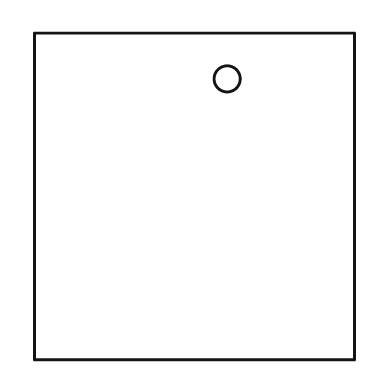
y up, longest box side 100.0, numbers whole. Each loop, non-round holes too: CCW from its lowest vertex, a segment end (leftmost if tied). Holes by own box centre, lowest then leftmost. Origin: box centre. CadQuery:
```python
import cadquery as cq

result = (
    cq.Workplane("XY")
    .moveTo(-49.0, -50.0)
    .lineTo(49.0, -50.0)
    .lineTo(49.0, 50.0)
    .lineTo(-49.0, 50.0)
    .close()
    .moveTo(10.0, 36.0)
    .circle(4.0)
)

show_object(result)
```